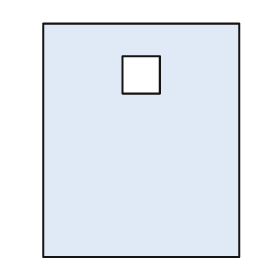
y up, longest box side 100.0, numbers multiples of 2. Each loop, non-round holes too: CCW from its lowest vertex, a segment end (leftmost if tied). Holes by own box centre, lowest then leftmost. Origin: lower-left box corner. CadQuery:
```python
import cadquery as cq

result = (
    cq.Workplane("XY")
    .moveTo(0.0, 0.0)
    .lineTo(84.0, 0.0)
    .lineTo(84.0, 100.0)
    .lineTo(0.0, 100.0)
    .close()
    .moveTo(34.0, 70.0)
    .lineTo(50.0, 70.0)
    .lineTo(50.0, 86.0)
    .lineTo(34.0, 86.0)
    .close()
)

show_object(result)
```